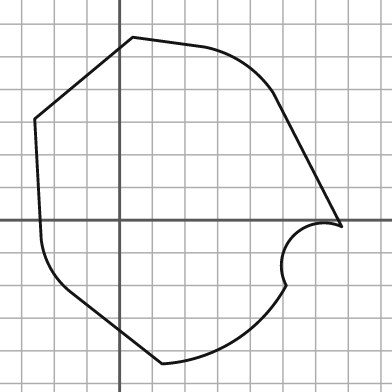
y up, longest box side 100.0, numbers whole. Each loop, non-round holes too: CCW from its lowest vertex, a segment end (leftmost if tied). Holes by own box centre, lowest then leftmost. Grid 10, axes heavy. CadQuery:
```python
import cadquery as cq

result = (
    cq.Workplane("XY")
    .moveTo(13.0, -44.0)
    .threePointArc((35.0, -37.0), (51.0, -20.0))
    .threePointArc((53.0, -5.0), (68.0, -2.0))
    .lineTo(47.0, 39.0)
    .threePointArc((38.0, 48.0), (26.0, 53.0))
    .lineTo(4.0, 56.0)
    .lineTo(-26.0, 31.0)
    .lineTo(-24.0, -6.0)
    .threePointArc((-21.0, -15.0), (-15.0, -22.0))
    .close()
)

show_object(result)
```